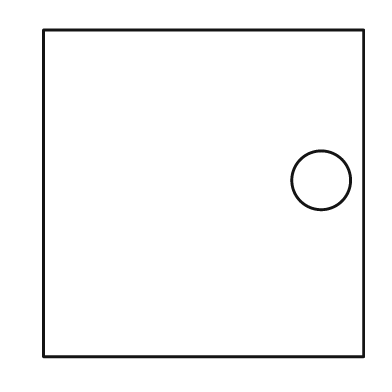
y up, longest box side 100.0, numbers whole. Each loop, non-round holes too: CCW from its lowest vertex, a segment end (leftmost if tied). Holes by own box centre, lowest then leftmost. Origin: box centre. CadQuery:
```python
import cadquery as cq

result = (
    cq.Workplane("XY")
    .moveTo(-49.0, -50.0)
    .lineTo(49.0, -50.0)
    .lineTo(49.0, 50.0)
    .lineTo(-49.0, 50.0)
    .close()
    .moveTo(36.0, 4.0)
    .circle(9.0)
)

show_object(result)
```